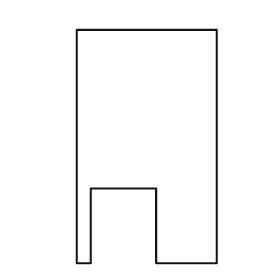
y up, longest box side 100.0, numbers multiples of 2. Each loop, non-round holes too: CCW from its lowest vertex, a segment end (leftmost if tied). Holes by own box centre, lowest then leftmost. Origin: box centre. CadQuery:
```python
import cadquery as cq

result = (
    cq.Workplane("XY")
    .moveTo(-30.0, -50.0)
    .lineTo(-24.0, -50.0)
    .lineTo(-24.0, -18.0)
    .lineTo(4.0, -18.0)
    .lineTo(4.0, -50.0)
    .lineTo(30.0, -50.0)
    .lineTo(30.0, 50.0)
    .lineTo(-30.0, 50.0)
    .close()
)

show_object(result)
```